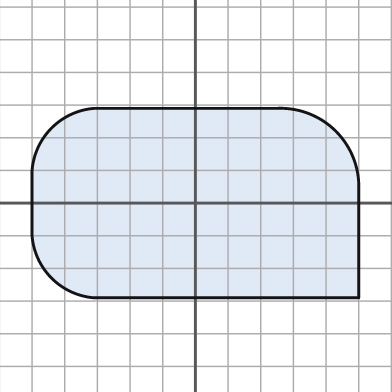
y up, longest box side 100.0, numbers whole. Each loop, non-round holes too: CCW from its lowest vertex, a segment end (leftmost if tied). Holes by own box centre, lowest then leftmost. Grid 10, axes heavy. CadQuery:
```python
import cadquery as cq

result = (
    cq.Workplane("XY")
    .moveTo(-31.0, -29.0)
    .lineTo(50.0, -29.0)
    .lineTo(50.0, 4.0)
    .threePointArc((43.0, 22.0), (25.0, 29.0))
    .lineTo(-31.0, 29.0)
    .threePointArc((-44.0, 23.0), (-50.0, 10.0))
    .lineTo(-50.0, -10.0)
    .threePointArc((-44.0, -23.0), (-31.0, -29.0))
    .close()
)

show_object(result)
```